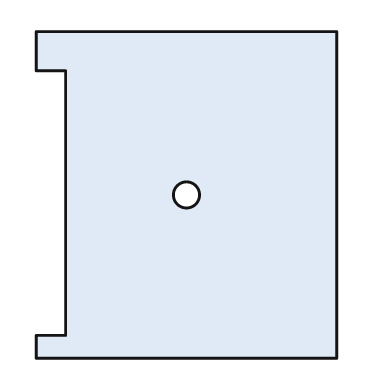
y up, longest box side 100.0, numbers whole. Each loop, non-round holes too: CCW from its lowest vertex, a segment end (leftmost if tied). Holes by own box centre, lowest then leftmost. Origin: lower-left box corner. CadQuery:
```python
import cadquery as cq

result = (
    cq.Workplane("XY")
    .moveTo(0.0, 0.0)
    .lineTo(92.0, 0.0)
    .lineTo(92.0, 100.0)
    .lineTo(0.0, 100.0)
    .lineTo(0.0, 88.0)
    .lineTo(9.0, 88.0)
    .lineTo(9.0, 7.0)
    .lineTo(0.0, 7.0)
    .close()
    .moveTo(46.0, 50.0)
    .circle(4.0)
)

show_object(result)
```